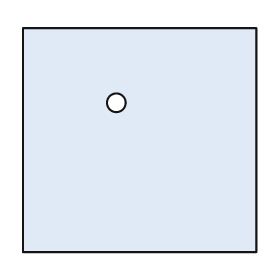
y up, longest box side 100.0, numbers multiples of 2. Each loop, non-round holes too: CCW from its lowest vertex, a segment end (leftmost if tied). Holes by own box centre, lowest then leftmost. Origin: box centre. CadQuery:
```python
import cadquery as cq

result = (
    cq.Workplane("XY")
    .moveTo(-50.0, -48.0)
    .lineTo(50.0, -48.0)
    .lineTo(50.0, 48.0)
    .lineTo(-50.0, 48.0)
    .close()
    .moveTo(-10.0, 16.0)
    .circle(4.0)
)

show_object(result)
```